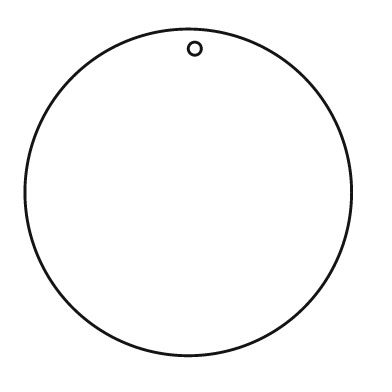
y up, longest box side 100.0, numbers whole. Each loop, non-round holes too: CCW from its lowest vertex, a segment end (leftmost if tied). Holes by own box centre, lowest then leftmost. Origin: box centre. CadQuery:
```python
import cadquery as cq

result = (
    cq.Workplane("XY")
    .moveTo(0.0, 0.0)
    .circle(50.0)
    .moveTo(2.0, 44.0)
    .circle(2.0)
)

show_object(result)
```